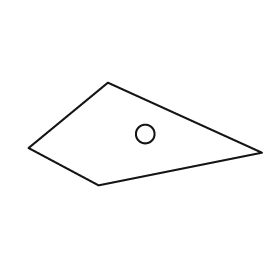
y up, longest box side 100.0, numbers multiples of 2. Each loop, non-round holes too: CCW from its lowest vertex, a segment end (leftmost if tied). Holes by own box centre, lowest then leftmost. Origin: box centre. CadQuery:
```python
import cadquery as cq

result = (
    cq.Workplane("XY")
    .moveTo(-20.0, -22.0)
    .lineTo(50.0, -8.0)
    .lineTo(-16.0, 22.0)
    .lineTo(-50.0, -6.0)
    .close()
    .moveTo(0.0, 0.0)
    .circle(4.0)
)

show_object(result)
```